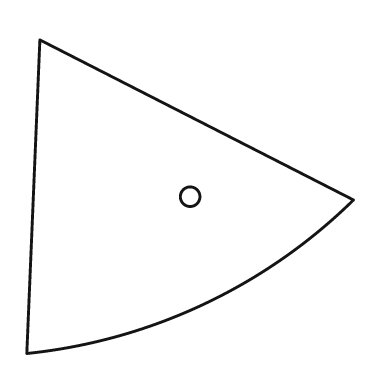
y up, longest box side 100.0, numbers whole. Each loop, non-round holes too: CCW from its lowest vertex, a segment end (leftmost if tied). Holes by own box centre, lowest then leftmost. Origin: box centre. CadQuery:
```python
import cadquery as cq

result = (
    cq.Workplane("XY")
    .moveTo(-50.0, -48.0)
    .threePointArc((4.0, -33.0), (50.0, -1.0))
    .lineTo(-46.0, 48.0)
    .close()
    .moveTo(0.0, 0.0)
    .circle(3.0)
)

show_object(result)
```